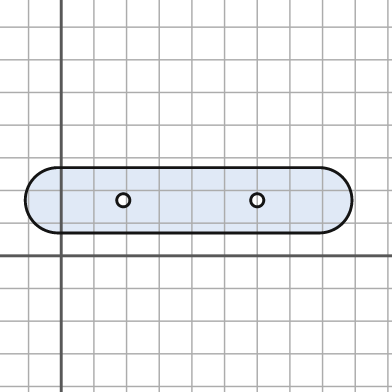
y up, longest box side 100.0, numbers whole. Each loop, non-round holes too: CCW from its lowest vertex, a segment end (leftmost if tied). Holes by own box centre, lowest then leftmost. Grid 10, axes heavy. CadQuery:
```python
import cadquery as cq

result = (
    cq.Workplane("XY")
    .moveTo(-1.0, 7.0)
    .lineTo(79.0, 7.0)
    .threePointArc((89.0, 17.0), (79.0, 27.0))
    .lineTo(-1.0, 27.0)
    .threePointArc((-11.0, 17.0), (-1.0, 7.0))
    .close()
    .moveTo(19.0, 17.0)
    .circle(2.0)
    .moveTo(60.0, 17.0)
    .circle(2.0)
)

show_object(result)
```